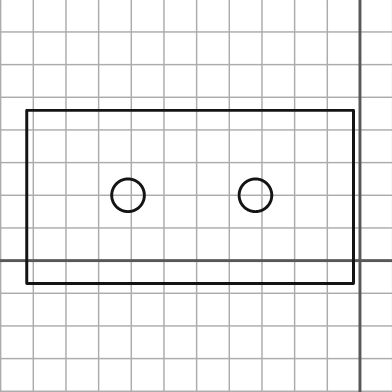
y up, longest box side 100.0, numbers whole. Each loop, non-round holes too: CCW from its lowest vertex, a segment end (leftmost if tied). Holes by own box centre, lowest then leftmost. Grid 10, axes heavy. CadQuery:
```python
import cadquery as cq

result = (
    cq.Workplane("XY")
    .moveTo(-102.0, -7.0)
    .lineTo(-2.0, -7.0)
    .lineTo(-2.0, 46.0)
    .lineTo(-102.0, 46.0)
    .close()
    .moveTo(-71.0, 20.0)
    .circle(5.0)
    .moveTo(-32.0, 20.0)
    .circle(5.0)
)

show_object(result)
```